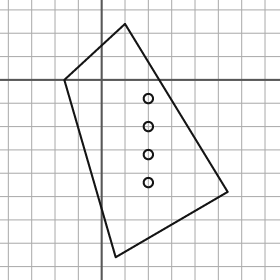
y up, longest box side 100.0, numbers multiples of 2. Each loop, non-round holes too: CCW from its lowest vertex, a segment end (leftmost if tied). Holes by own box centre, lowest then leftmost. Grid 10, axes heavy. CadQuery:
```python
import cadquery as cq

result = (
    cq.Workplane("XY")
    .moveTo(6.0, -76.0)
    .lineTo(54.0, -48.0)
    .lineTo(10.0, 24.0)
    .lineTo(-16.0, 0.0)
    .close()
    .moveTo(20.0, -44.0)
    .circle(2.0)
    .moveTo(20.0, -32.0)
    .circle(2.0)
    .moveTo(20.0, -20.0)
    .circle(2.0)
    .moveTo(20.0, -8.0)
    .circle(2.0)
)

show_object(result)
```